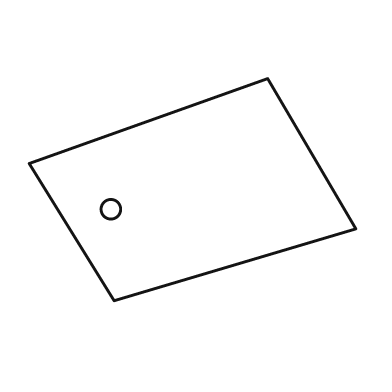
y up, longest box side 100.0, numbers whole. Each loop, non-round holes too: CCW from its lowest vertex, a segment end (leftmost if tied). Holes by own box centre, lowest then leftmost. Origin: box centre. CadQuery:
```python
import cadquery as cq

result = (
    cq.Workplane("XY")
    .moveTo(-24.0, -34.0)
    .lineTo(50.0, -12.0)
    .lineTo(23.0, 34.0)
    .lineTo(-50.0, 8.0)
    .close()
    .moveTo(-25.0, -6.0)
    .circle(3.0)
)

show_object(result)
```